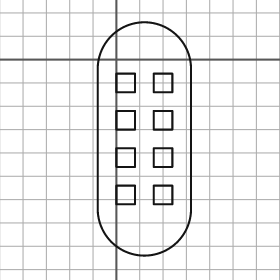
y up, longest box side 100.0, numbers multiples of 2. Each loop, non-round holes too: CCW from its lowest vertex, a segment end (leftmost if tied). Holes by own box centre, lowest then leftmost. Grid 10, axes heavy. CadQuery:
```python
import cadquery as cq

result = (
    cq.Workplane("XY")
    .moveTo(-8.0, -64.0)
    .threePointArc((12.0, -84.0), (32.0, -64.0))
    .lineTo(32.0, -4.0)
    .threePointArc((12.0, 16.0), (-8.0, -4.0))
    .close()
    .moveTo(0.0, -62.0)
    .lineTo(8.0, -62.0)
    .lineTo(8.0, -54.0)
    .lineTo(0.0, -54.0)
    .close()
    .moveTo(16.0, -62.0)
    .lineTo(24.0, -62.0)
    .lineTo(24.0, -54.0)
    .lineTo(16.0, -54.0)
    .close()
    .moveTo(0.0, -46.0)
    .lineTo(8.0, -46.0)
    .lineTo(8.0, -38.0)
    .lineTo(0.0, -38.0)
    .close()
    .moveTo(16.0, -46.0)
    .lineTo(24.0, -46.0)
    .lineTo(24.0, -38.0)
    .lineTo(16.0, -38.0)
    .close()
    .moveTo(0.0, -30.0)
    .lineTo(8.0, -30.0)
    .lineTo(8.0, -22.0)
    .lineTo(0.0, -22.0)
    .close()
    .moveTo(16.0, -30.0)
    .lineTo(24.0, -30.0)
    .lineTo(24.0, -22.0)
    .lineTo(16.0, -22.0)
    .close()
    .moveTo(0.0, -14.0)
    .lineTo(8.0, -14.0)
    .lineTo(8.0, -6.0)
    .lineTo(0.0, -6.0)
    .close()
    .moveTo(16.0, -14.0)
    .lineTo(24.0, -14.0)
    .lineTo(24.0, -6.0)
    .lineTo(16.0, -6.0)
    .close()
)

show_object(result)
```